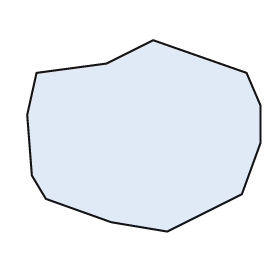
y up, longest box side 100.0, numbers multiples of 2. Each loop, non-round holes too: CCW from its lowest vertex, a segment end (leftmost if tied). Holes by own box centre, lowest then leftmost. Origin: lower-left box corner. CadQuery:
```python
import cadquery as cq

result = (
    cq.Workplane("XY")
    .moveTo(60.0, 0.0)
    .lineTo(92.0, 16.0)
    .lineTo(100.0, 38.0)
    .lineTo(100.0, 54.0)
    .lineTo(94.0, 68.0)
    .lineTo(54.0, 82.0)
    .lineTo(34.0, 72.0)
    .lineTo(4.0, 68.0)
    .lineTo(0.0, 50.0)
    .lineTo(2.0, 24.0)
    .lineTo(8.0, 14.0)
    .lineTo(36.0, 4.0)
    .close()
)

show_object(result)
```